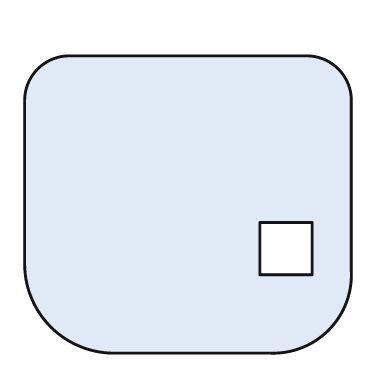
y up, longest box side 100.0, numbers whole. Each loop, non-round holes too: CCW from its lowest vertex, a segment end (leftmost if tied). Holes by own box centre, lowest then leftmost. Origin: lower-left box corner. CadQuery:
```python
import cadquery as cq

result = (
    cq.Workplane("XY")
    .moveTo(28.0, 0.0)
    .lineTo(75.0, 0.0)
    .threePointArc((93.0, 7.0), (100.0, 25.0))
    .lineTo(100.0, 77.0)
    .threePointArc((96.0, 87.0), (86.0, 91.0))
    .lineTo(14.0, 91.0)
    .threePointArc((4.0, 87.0), (0.0, 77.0))
    .lineTo(0.0, 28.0)
    .threePointArc((8.0, 8.0), (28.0, 0.0))
    .close()
    .moveTo(72.0, 24.0)
    .lineTo(88.0, 24.0)
    .lineTo(88.0, 40.0)
    .lineTo(72.0, 40.0)
    .close()
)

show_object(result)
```